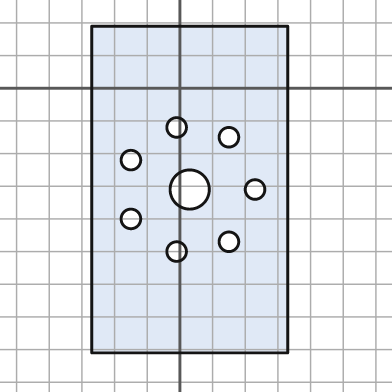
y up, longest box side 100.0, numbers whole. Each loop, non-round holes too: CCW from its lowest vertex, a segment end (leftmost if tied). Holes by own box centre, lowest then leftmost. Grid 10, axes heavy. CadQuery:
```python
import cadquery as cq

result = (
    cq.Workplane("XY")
    .moveTo(-27.0, -81.0)
    .lineTo(33.0, -81.0)
    .lineTo(33.0, 19.0)
    .lineTo(-27.0, 19.0)
    .close()
    .moveTo(-1.0, -50.0)
    .circle(3.0)
    .moveTo(15.0, -47.0)
    .circle(3.0)
    .moveTo(-15.0, -40.0)
    .circle(3.0)
    .moveTo(3.0, -31.0)
    .circle(6.0)
    .moveTo(23.0, -31.0)
    .circle(3.0)
    .moveTo(-15.0, -22.0)
    .circle(3.0)
    .moveTo(15.0, -15.0)
    .circle(3.0)
    .moveTo(-1.0, -12.0)
    .circle(3.0)
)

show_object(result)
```